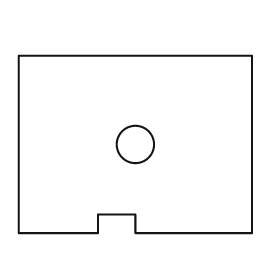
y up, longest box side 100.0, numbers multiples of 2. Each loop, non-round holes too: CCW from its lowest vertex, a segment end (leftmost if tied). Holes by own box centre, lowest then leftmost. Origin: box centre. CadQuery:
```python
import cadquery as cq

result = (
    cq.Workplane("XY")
    .moveTo(-50.0, -38.0)
    .lineTo(-16.0, -38.0)
    .lineTo(-16.0, -30.0)
    .lineTo(0.0, -30.0)
    .lineTo(0.0, -38.0)
    .lineTo(50.0, -38.0)
    .lineTo(50.0, 38.0)
    .lineTo(-50.0, 38.0)
    .close()
    .moveTo(0.0, 0.0)
    .circle(8.0)
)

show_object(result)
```